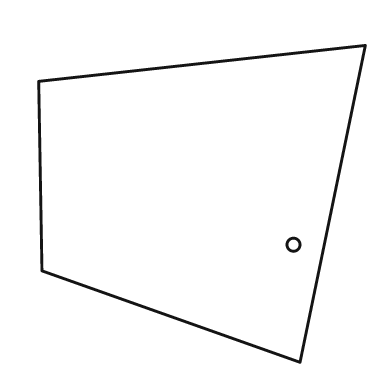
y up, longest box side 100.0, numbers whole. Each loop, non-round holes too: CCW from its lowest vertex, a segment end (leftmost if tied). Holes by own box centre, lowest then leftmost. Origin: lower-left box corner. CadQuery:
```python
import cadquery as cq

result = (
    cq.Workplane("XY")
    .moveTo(80.0, 0.0)
    .lineTo(100.0, 97.0)
    .lineTo(0.0, 86.0)
    .lineTo(1.0, 28.0)
    .close()
    .moveTo(78.0, 36.0)
    .circle(2.0)
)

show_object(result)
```